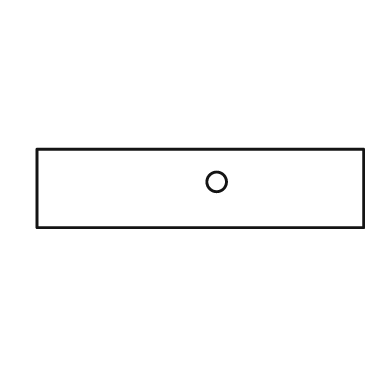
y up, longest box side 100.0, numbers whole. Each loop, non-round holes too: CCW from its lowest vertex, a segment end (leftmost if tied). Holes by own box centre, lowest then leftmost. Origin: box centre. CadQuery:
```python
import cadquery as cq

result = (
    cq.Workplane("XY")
    .moveTo(-50.0, -12.0)
    .lineTo(50.0, -12.0)
    .lineTo(50.0, 12.0)
    .lineTo(-50.0, 12.0)
    .close()
    .moveTo(5.0, 2.0)
    .circle(3.0)
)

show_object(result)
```